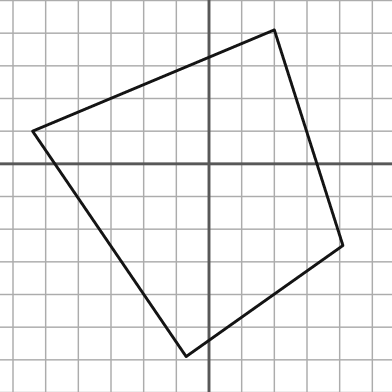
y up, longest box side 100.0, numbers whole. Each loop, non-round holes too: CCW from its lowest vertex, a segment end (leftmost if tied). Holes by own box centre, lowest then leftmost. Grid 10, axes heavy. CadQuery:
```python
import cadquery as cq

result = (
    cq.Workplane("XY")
    .moveTo(-7.0, -59.0)
    .lineTo(41.0, -25.0)
    .lineTo(20.0, 41.0)
    .lineTo(-54.0, 10.0)
    .close()
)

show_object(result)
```